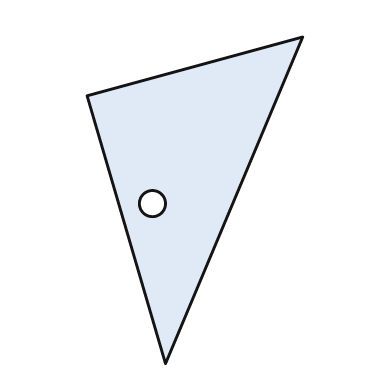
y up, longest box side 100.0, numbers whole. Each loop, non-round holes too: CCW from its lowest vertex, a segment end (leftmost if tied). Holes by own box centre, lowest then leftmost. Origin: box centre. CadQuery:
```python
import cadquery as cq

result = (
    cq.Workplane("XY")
    .moveTo(-9.0, -50.0)
    .lineTo(33.0, 50.0)
    .lineTo(-33.0, 32.0)
    .close()
    .moveTo(-13.0, -1.0)
    .circle(4.0)
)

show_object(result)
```